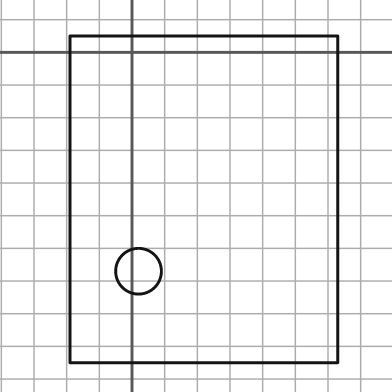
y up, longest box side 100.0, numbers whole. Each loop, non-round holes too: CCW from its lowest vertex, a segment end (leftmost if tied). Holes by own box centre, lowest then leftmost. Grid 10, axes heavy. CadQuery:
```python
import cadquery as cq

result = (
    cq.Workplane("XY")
    .moveTo(-19.0, -95.0)
    .lineTo(63.0, -95.0)
    .lineTo(63.0, 5.0)
    .lineTo(-19.0, 5.0)
    .close()
    .moveTo(2.0, -67.0)
    .circle(7.0)
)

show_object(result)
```